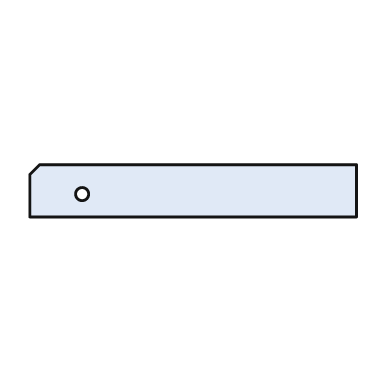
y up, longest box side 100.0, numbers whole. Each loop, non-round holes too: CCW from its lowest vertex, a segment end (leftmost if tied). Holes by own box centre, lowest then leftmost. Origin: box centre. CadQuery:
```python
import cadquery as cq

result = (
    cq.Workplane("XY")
    .moveTo(-50.0, -8.0)
    .lineTo(50.0, -8.0)
    .lineTo(50.0, 8.0)
    .lineTo(-47.0, 8.0)
    .lineTo(-50.0, 5.0)
    .close()
    .moveTo(-34.0, -1.0)
    .circle(2.0)
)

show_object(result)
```